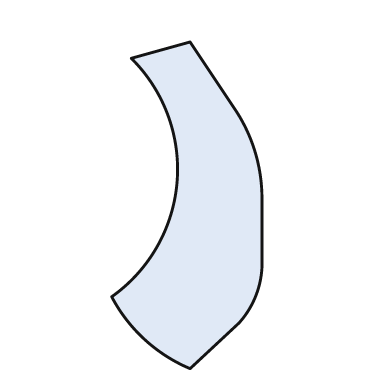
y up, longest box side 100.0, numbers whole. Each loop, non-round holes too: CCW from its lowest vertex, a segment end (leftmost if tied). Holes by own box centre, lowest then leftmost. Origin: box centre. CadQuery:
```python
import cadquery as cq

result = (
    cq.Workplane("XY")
    .moveTo(1.0, -50.0)
    .lineTo(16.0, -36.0)
    .threePointArc((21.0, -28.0), (23.0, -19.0))
    .lineTo(23.0, 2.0)
    .threePointArc((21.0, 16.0), (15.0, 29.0))
    .lineTo(1.0, 50.0)
    .lineTo(-17.0, 45.0)
    .threePointArc((-3.0, 7.0), (-23.0, -28.0))
    .threePointArc((-13.0, -41.0), (1.0, -50.0))
    .close()
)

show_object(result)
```